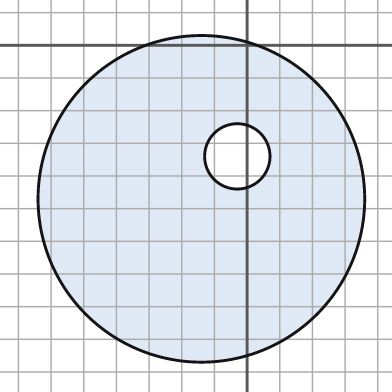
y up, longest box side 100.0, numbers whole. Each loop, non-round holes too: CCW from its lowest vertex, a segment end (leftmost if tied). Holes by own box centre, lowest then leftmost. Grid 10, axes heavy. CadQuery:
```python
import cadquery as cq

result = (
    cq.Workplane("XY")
    .moveTo(-14.0, -47.0)
    .circle(50.0)
    .moveTo(-3.0, -34.0)
    .circle(10.0)
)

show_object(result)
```